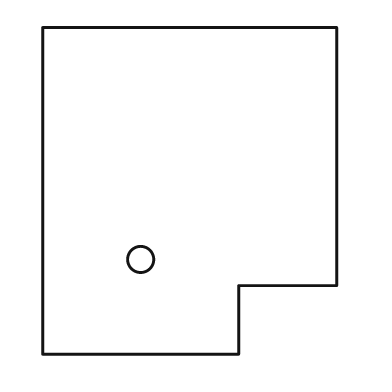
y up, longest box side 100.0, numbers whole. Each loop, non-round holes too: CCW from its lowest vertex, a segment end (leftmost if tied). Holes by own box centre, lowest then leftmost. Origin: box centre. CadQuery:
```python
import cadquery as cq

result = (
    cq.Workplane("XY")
    .moveTo(-45.0, -50.0)
    .lineTo(15.0, -50.0)
    .lineTo(15.0, -29.0)
    .lineTo(45.0, -29.0)
    .lineTo(45.0, 50.0)
    .lineTo(-45.0, 50.0)
    .close()
    .moveTo(-15.0, -21.0)
    .circle(4.0)
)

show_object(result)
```